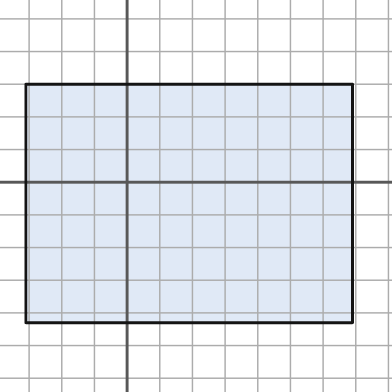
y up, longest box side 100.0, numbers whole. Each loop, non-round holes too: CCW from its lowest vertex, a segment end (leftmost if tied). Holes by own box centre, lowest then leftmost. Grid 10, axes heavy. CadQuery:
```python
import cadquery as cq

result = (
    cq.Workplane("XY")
    .moveTo(-31.0, -43.0)
    .lineTo(69.0, -43.0)
    .lineTo(69.0, 30.0)
    .lineTo(-31.0, 30.0)
    .close()
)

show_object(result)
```